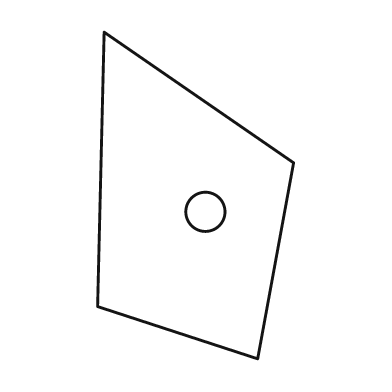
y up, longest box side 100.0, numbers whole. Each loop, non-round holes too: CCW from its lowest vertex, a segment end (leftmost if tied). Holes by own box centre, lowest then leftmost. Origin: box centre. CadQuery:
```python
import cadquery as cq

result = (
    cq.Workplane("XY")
    .moveTo(19.0, -50.0)
    .lineTo(30.0, 10.0)
    .lineTo(-28.0, 50.0)
    .lineTo(-30.0, -34.0)
    .close()
    .moveTo(3.0, -5.0)
    .circle(6.0)
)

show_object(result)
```